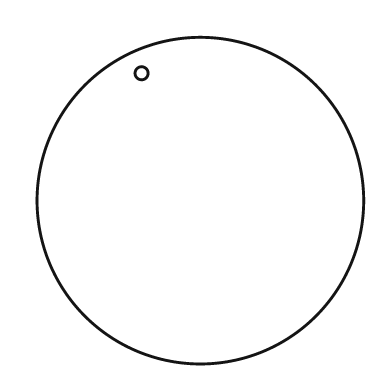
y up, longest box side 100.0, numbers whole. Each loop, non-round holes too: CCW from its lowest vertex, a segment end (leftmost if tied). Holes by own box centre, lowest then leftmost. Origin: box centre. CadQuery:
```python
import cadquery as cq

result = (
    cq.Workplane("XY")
    .moveTo(0.0, 0.0)
    .circle(50.0)
    .moveTo(-18.0, 39.0)
    .circle(2.0)
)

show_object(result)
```